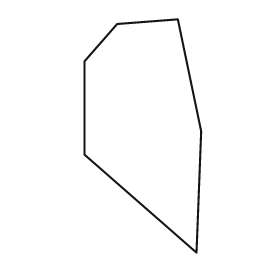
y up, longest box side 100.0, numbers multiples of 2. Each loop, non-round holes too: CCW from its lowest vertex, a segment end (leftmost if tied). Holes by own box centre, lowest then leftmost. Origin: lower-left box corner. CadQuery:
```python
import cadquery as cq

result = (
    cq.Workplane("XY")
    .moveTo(48.0, 0.0)
    .lineTo(50.0, 52.0)
    .lineTo(40.0, 100.0)
    .lineTo(14.0, 98.0)
    .lineTo(0.0, 82.0)
    .lineTo(0.0, 42.0)
    .close()
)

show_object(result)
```